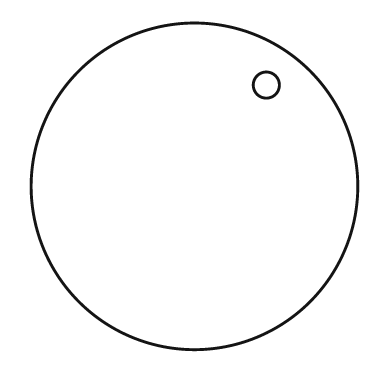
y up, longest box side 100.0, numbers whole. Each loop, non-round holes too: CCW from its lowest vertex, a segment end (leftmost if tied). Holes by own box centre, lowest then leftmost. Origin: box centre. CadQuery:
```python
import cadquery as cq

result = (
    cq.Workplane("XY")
    .moveTo(0.0, 0.0)
    .circle(50.0)
    .moveTo(22.0, 31.0)
    .circle(4.0)
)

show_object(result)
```